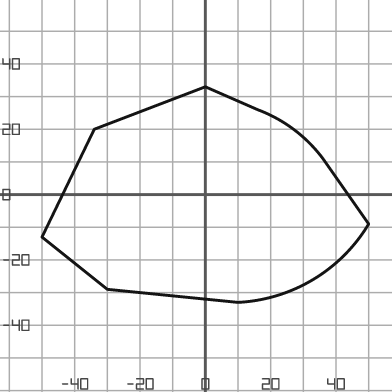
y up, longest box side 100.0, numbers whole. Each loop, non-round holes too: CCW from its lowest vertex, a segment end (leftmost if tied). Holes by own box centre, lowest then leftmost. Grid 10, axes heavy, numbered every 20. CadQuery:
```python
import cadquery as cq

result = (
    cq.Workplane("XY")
    .moveTo(10.0, -33.0)
    .threePointArc((33.0, -26.0), (50.0, -9.0))
    .lineTo(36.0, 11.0)
    .threePointArc((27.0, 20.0), (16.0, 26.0))
    .lineTo(0.0, 33.0)
    .lineTo(-34.0, 20.0)
    .lineTo(-50.0, -13.0)
    .lineTo(-30.0, -29.0)
    .close()
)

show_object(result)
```